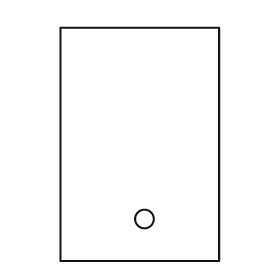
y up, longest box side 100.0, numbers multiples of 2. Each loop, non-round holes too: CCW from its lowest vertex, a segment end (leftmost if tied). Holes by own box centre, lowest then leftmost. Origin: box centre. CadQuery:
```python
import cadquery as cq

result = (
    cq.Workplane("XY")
    .moveTo(-34.0, -50.0)
    .lineTo(34.0, -50.0)
    .lineTo(34.0, 50.0)
    .lineTo(-34.0, 50.0)
    .close()
    .moveTo(2.0, -32.0)
    .circle(4.0)
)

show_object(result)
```